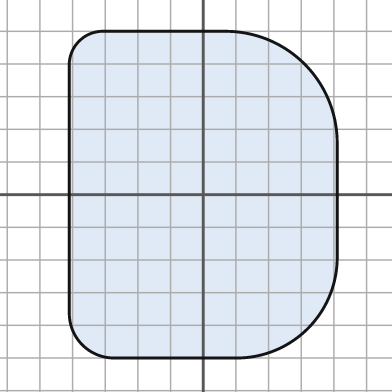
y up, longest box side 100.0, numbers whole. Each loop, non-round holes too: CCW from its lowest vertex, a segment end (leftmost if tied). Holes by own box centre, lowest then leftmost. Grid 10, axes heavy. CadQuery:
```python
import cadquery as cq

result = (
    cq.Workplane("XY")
    .moveTo(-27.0, -50.0)
    .lineTo(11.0, -50.0)
    .threePointArc((32.0, -41.0), (41.0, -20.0))
    .lineTo(41.0, 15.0)
    .threePointArc((31.0, 40.0), (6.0, 50.0))
    .lineTo(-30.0, 50.0)
    .threePointArc((-38.0, 47.0), (-41.0, 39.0))
    .lineTo(-41.0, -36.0)
    .threePointArc((-37.0, -46.0), (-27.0, -50.0))
    .close()
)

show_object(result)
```